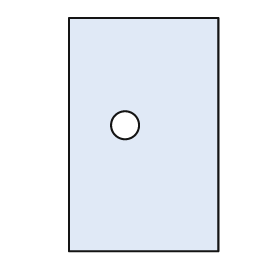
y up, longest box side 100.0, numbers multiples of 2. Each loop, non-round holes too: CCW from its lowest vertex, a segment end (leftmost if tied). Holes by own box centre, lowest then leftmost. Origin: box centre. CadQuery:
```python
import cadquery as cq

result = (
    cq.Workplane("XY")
    .moveTo(-32.0, -50.0)
    .lineTo(32.0, -50.0)
    .lineTo(32.0, 50.0)
    .lineTo(-32.0, 50.0)
    .close()
    .moveTo(-8.0, 4.0)
    .circle(6.0)
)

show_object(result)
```